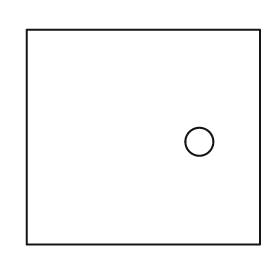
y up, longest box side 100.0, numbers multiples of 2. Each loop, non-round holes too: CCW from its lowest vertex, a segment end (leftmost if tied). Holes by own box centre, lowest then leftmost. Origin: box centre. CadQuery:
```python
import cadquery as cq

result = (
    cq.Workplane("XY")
    .moveTo(-50.0, -46.0)
    .lineTo(50.0, -46.0)
    .lineTo(50.0, 46.0)
    .lineTo(-50.0, 46.0)
    .close()
    .moveTo(24.0, -2.0)
    .circle(6.0)
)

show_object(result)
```